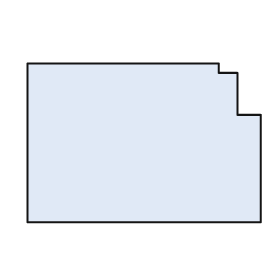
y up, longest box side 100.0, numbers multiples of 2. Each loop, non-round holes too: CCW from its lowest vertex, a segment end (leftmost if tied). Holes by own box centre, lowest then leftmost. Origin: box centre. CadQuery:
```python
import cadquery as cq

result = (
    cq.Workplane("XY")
    .moveTo(-50.0, -34.0)
    .lineTo(50.0, -34.0)
    .lineTo(50.0, 12.0)
    .lineTo(40.0, 12.0)
    .lineTo(40.0, 30.0)
    .lineTo(32.0, 30.0)
    .lineTo(32.0, 34.0)
    .lineTo(-50.0, 34.0)
    .close()
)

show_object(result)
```